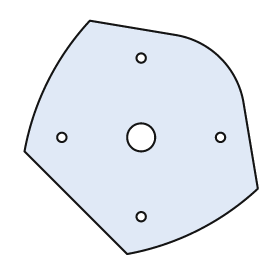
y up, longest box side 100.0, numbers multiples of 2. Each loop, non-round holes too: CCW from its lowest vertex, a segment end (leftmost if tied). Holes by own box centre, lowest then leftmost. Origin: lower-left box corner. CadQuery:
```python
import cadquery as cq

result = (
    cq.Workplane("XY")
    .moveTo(44.0, 0.0)
    .threePointArc((74.0, 10.0), (100.0, 28.0))
    .lineTo(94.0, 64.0)
    .threePointArc((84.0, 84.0), (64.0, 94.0))
    .lineTo(28.0, 100.0)
    .threePointArc((10.0, 74.0), (0.0, 44.0))
    .close()
    .moveTo(50.0, 16.0)
    .circle(2.0)
    .moveTo(16.0, 50.0)
    .circle(2.0)
    .moveTo(50.0, 50.0)
    .circle(6.0)
    .moveTo(84.0, 50.0)
    .circle(2.0)
    .moveTo(50.0, 84.0)
    .circle(2.0)
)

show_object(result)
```